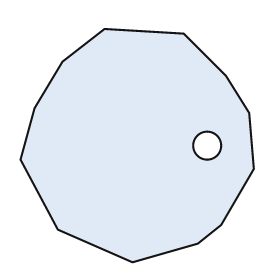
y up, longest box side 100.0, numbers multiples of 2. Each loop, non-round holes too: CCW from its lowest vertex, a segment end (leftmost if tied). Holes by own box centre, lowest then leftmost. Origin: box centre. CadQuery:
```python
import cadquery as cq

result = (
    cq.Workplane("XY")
    .moveTo(-2.0, -50.0)
    .lineTo(26.0, -42.0)
    .lineTo(36.0, -34.0)
    .lineTo(50.0, -10.0)
    .lineTo(48.0, 14.0)
    .lineTo(38.0, 30.0)
    .lineTo(20.0, 48.0)
    .lineTo(-14.0, 50.0)
    .lineTo(-32.0, 36.0)
    .lineTo(-44.0, 16.0)
    .lineTo(-50.0, -6.0)
    .lineTo(-34.0, -36.0)
    .close()
    .moveTo(30.0, 0.0)
    .circle(6.0)
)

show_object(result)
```